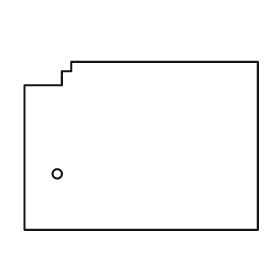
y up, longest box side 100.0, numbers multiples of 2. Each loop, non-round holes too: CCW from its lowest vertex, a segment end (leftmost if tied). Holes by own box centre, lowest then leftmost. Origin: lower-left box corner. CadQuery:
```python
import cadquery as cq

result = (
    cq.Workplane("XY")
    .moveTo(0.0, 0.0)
    .lineTo(100.0, 0.0)
    .lineTo(100.0, 72.0)
    .lineTo(20.0, 72.0)
    .lineTo(20.0, 68.0)
    .lineTo(16.0, 68.0)
    .lineTo(16.0, 62.0)
    .lineTo(0.0, 62.0)
    .close()
    .moveTo(14.0, 24.0)
    .circle(2.0)
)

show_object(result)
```